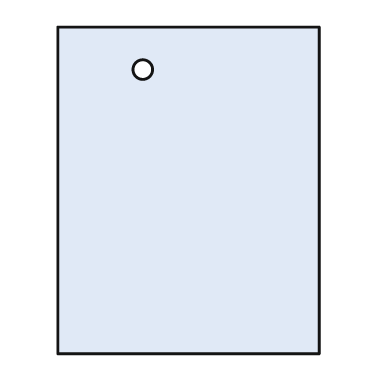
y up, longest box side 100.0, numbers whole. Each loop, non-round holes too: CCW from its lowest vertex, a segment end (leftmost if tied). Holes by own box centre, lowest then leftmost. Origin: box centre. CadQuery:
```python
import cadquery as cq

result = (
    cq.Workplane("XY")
    .moveTo(-40.0, -50.0)
    .lineTo(40.0, -50.0)
    .lineTo(40.0, 50.0)
    .lineTo(-40.0, 50.0)
    .close()
    .moveTo(-14.0, 37.0)
    .circle(3.0)
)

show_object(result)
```